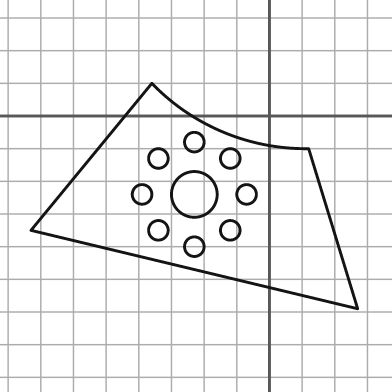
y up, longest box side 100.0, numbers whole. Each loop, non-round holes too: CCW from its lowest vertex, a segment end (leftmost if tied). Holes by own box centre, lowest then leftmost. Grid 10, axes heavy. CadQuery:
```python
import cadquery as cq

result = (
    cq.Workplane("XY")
    .moveTo(27.0, -59.0)
    .lineTo(12.0, -10.0)
    .threePointArc((-14.0, -5.0), (-36.0, 10.0))
    .lineTo(-73.0, -35.0)
    .close()
    .moveTo(-23.0, -40.0)
    .circle(3.0)
    .moveTo(-34.0, -35.0)
    .circle(3.0)
    .moveTo(-12.0, -35.0)
    .circle(3.0)
    .moveTo(-39.0, -24.0)
    .circle(3.0)
    .moveTo(-23.0, -24.0)
    .circle(7.0)
    .moveTo(-7.0, -24.0)
    .circle(3.0)
    .moveTo(-34.0, -13.0)
    .circle(3.0)
    .moveTo(-12.0, -13.0)
    .circle(3.0)
    .moveTo(-23.0, -8.0)
    .circle(3.0)
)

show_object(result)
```